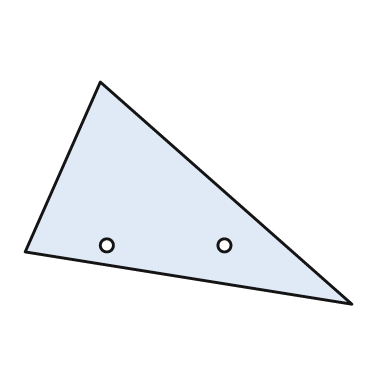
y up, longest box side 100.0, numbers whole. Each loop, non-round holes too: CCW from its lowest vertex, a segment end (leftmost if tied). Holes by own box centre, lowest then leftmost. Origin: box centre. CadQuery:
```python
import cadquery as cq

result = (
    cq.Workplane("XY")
    .moveTo(50.0, -34.0)
    .lineTo(-27.0, 34.0)
    .lineTo(-50.0, -18.0)
    .close()
    .moveTo(-25.0, -16.0)
    .circle(2.0)
    .moveTo(11.0, -16.0)
    .circle(2.0)
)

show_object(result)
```